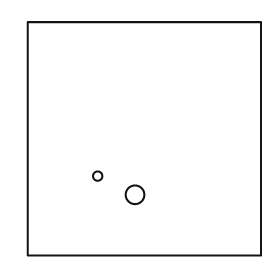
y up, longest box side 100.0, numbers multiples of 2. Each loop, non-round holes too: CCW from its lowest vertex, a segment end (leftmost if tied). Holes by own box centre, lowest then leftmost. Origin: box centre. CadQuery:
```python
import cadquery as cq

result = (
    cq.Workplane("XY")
    .moveTo(-50.0, -50.0)
    .lineTo(50.0, -50.0)
    .lineTo(50.0, 50.0)
    .lineTo(-50.0, 50.0)
    .close()
    .moveTo(-4.0, -24.0)
    .circle(4.0)
    .moveTo(-20.0, -16.0)
    .circle(2.0)
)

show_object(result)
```